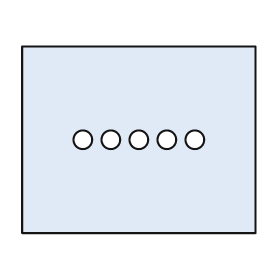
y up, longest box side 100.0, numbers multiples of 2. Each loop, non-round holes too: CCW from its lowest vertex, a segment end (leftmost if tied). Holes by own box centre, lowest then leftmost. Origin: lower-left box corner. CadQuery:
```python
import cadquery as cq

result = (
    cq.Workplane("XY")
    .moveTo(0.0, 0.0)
    .lineTo(100.0, 0.0)
    .lineTo(100.0, 80.0)
    .lineTo(0.0, 80.0)
    .close()
    .moveTo(26.0, 40.0)
    .circle(4.0)
    .moveTo(38.0, 40.0)
    .circle(4.0)
    .moveTo(50.0, 40.0)
    .circle(4.0)
    .moveTo(62.0, 40.0)
    .circle(4.0)
    .moveTo(74.0, 40.0)
    .circle(4.0)
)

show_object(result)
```